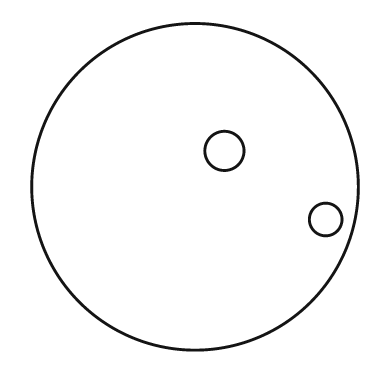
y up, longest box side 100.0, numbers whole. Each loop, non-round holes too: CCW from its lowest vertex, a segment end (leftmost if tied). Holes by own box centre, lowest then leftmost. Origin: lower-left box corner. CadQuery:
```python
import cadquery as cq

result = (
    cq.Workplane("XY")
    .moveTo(50.0, 50.0)
    .circle(50.0)
    .moveTo(90.0, 40.0)
    .circle(5.0)
    .moveTo(59.0, 61.0)
    .circle(6.0)
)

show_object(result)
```